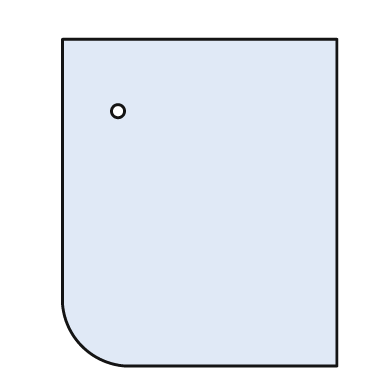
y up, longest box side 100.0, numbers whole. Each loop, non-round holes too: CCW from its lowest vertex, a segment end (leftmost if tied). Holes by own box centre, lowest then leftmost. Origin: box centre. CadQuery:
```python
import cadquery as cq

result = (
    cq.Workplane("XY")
    .moveTo(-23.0, -50.0)
    .lineTo(42.0, -50.0)
    .lineTo(42.0, 50.0)
    .lineTo(-42.0, 50.0)
    .lineTo(-42.0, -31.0)
    .threePointArc((-36.0, -44.0), (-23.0, -50.0))
    .close()
    .moveTo(-25.0, 28.0)
    .circle(2.0)
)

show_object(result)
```